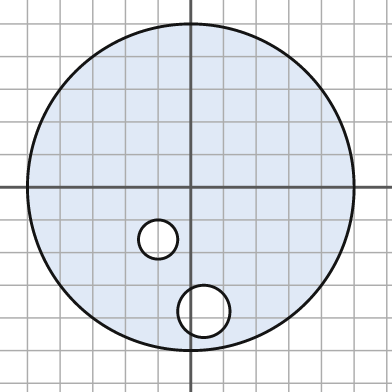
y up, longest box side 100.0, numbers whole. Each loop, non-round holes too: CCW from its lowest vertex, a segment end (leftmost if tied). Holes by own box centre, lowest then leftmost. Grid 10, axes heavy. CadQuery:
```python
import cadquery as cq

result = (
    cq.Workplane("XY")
    .moveTo(0.0, 0.0)
    .circle(50.0)
    .moveTo(4.0, -38.0)
    .circle(8.0)
    .moveTo(-10.0, -16.0)
    .circle(6.0)
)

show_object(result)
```